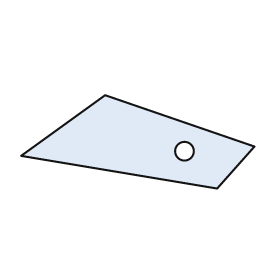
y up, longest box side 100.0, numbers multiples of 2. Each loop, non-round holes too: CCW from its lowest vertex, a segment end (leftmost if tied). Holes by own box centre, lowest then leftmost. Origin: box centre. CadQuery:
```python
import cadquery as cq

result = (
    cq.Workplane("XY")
    .moveTo(34.0, -20.0)
    .lineTo(50.0, -2.0)
    .lineTo(-14.0, 20.0)
    .lineTo(-50.0, -6.0)
    .close()
    .moveTo(20.0, -4.0)
    .circle(4.0)
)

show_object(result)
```